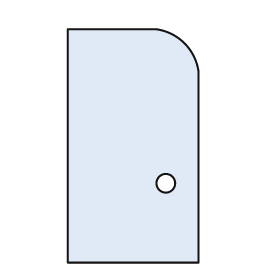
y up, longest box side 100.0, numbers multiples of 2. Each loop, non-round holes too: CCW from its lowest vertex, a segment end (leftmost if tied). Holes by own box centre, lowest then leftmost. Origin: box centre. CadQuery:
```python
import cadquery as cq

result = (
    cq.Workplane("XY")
    .moveTo(-28.0, -50.0)
    .lineTo(28.0, -50.0)
    .lineTo(28.0, 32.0)
    .threePointArc((22.0, 44.0), (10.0, 50.0))
    .lineTo(-28.0, 50.0)
    .close()
    .moveTo(14.0, -16.0)
    .circle(4.0)
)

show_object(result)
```